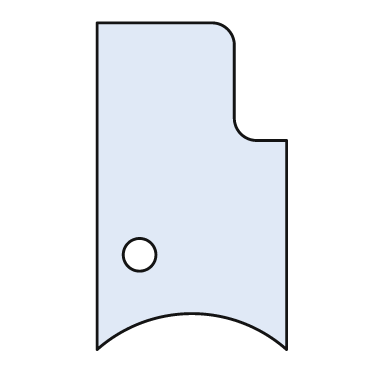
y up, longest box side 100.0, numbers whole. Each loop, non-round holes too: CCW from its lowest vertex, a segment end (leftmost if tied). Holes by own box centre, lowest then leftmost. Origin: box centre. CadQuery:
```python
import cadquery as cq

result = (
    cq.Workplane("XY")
    .moveTo(-29.0, -50.0)
    .threePointArc((0.0, -39.0), (29.0, -50.0))
    .lineTo(29.0, 14.0)
    .lineTo(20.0, 14.0)
    .threePointArc((15.0, 16.0), (13.0, 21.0))
    .lineTo(13.0, 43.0)
    .threePointArc((11.0, 48.0), (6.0, 50.0))
    .lineTo(-29.0, 50.0)
    .close()
    .moveTo(-16.0, -21.0)
    .circle(5.0)
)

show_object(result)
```